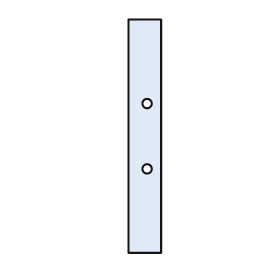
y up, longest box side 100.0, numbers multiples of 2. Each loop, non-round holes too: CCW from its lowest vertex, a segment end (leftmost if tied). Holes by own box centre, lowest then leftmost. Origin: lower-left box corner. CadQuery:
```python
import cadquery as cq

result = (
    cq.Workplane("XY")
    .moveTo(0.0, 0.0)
    .lineTo(14.0, 0.0)
    .lineTo(14.0, 100.0)
    .lineTo(0.0, 100.0)
    .close()
    .moveTo(8.0, 36.0)
    .circle(2.0)
    .moveTo(8.0, 64.0)
    .circle(2.0)
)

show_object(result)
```